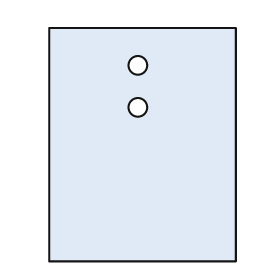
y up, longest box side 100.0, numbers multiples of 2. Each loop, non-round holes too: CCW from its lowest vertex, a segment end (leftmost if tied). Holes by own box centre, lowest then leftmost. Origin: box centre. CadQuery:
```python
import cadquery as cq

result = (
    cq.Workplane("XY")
    .moveTo(-40.0, -50.0)
    .lineTo(40.0, -50.0)
    .lineTo(40.0, 50.0)
    .lineTo(-40.0, 50.0)
    .close()
    .moveTo(-2.0, 16.0)
    .circle(4.0)
    .moveTo(-2.0, 34.0)
    .circle(4.0)
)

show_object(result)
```